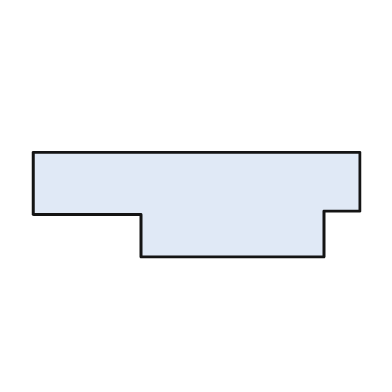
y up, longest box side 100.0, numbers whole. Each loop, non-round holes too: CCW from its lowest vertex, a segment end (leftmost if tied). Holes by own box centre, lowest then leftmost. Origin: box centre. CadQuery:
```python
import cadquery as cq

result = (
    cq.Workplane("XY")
    .moveTo(-17.0, -16.0)
    .lineTo(39.0, -16.0)
    .lineTo(39.0, -2.0)
    .lineTo(50.0, -2.0)
    .lineTo(50.0, 16.0)
    .lineTo(-50.0, 16.0)
    .lineTo(-50.0, -3.0)
    .lineTo(-17.0, -3.0)
    .close()
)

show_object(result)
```